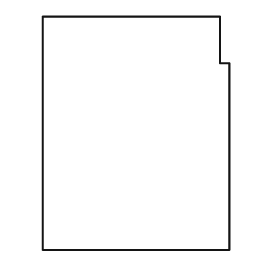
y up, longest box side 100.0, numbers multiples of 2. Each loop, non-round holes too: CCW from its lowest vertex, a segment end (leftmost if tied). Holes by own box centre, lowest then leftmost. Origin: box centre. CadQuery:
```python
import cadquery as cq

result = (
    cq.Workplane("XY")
    .moveTo(-40.0, -50.0)
    .lineTo(40.0, -50.0)
    .lineTo(40.0, 30.0)
    .lineTo(36.0, 30.0)
    .lineTo(36.0, 50.0)
    .lineTo(-40.0, 50.0)
    .close()
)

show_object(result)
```